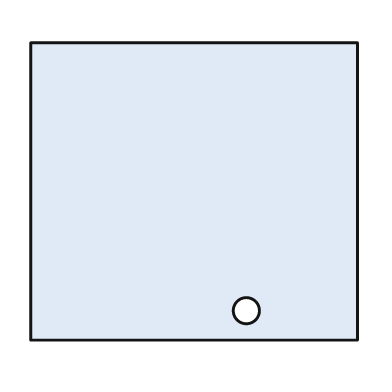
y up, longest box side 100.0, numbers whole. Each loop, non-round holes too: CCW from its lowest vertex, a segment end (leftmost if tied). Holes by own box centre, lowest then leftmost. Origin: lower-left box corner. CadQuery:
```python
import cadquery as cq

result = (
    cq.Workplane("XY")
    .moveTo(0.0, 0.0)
    .lineTo(100.0, 0.0)
    .lineTo(100.0, 91.0)
    .lineTo(0.0, 91.0)
    .close()
    .moveTo(66.0, 9.0)
    .circle(4.0)
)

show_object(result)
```